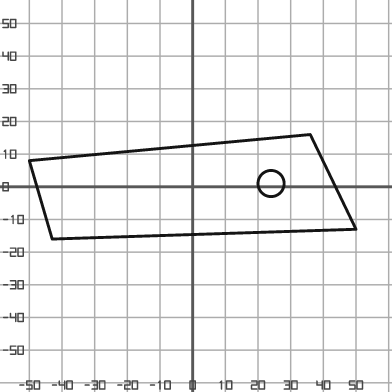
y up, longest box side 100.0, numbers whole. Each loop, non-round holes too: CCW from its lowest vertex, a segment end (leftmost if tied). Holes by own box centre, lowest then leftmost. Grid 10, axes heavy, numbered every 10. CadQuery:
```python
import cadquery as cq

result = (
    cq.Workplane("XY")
    .moveTo(-43.0, -16.0)
    .lineTo(50.0, -13.0)
    .lineTo(36.0, 16.0)
    .lineTo(-50.0, 8.0)
    .close()
    .moveTo(24.0, 1.0)
    .circle(4.0)
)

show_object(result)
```